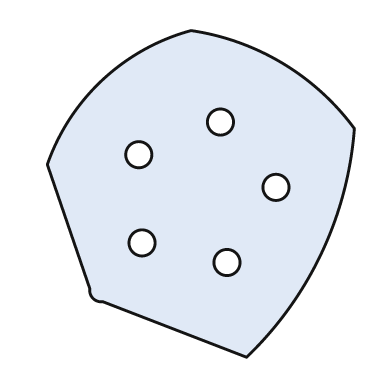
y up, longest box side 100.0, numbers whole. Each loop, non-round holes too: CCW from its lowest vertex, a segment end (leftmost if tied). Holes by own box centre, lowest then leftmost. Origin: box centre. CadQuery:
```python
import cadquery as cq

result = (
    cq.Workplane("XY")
    .moveTo(14.0, -50.0)
    .threePointArc((37.0, -18.0), (47.0, 20.0))
    .threePointArc((25.0, 40.0), (-3.0, 50.0))
    .threePointArc((-30.0, 35.0), (-47.0, 9.0))
    .lineTo(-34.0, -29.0)
    .threePointArc((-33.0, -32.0), (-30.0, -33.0))
    .close()
    .moveTo(8.0, -21.0)
    .circle(4.0)
    .moveTo(-18.0, -15.0)
    .circle(4.0)
    .moveTo(23.0, 2.0)
    .circle(4.0)
    .moveTo(-19.0, 12.0)
    .circle(4.0)
    .moveTo(6.0, 22.0)
    .circle(4.0)
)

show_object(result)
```